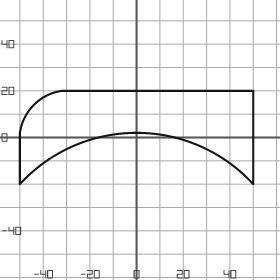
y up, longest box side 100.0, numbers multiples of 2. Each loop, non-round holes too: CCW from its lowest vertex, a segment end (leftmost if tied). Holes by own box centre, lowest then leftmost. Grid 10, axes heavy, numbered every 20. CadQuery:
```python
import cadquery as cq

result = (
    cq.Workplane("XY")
    .moveTo(-50.0, -20.0)
    .threePointArc((0.0, 2.0), (50.0, -20.0))
    .lineTo(50.0, 20.0)
    .lineTo(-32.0, 20.0)
    .threePointArc((-44.0, 14.0), (-50.0, 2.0))
    .close()
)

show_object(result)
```